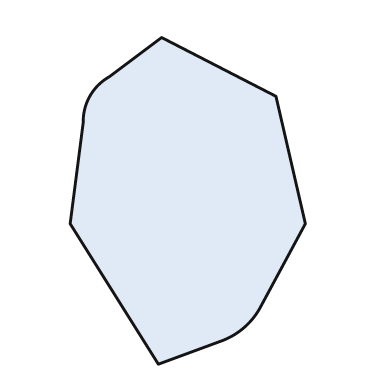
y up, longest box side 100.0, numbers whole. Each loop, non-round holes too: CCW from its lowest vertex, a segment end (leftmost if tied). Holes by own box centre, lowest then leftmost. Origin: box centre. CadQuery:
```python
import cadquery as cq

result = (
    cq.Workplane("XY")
    .moveTo(-9.0, -50.0)
    .lineTo(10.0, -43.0)
    .threePointArc((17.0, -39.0), (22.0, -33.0))
    .lineTo(36.0, -7.0)
    .lineTo(27.0, 32.0)
    .lineTo(-8.0, 50.0)
    .lineTo(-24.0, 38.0)
    .threePointArc((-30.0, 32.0), (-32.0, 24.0))
    .lineTo(-36.0, -7.0)
    .close()
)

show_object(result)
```